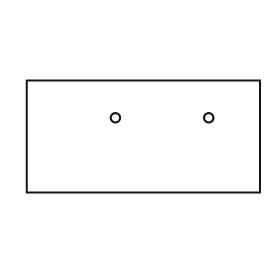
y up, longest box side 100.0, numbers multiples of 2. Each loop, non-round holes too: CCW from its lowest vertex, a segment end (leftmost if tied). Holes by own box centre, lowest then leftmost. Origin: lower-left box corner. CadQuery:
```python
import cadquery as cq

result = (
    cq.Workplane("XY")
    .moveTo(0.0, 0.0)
    .lineTo(100.0, 0.0)
    .lineTo(100.0, 48.0)
    .lineTo(0.0, 48.0)
    .close()
    .moveTo(38.0, 32.0)
    .circle(2.0)
    .moveTo(78.0, 32.0)
    .circle(2.0)
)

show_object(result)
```